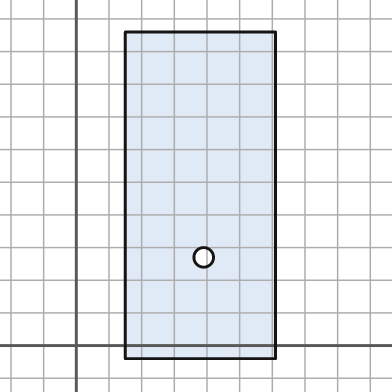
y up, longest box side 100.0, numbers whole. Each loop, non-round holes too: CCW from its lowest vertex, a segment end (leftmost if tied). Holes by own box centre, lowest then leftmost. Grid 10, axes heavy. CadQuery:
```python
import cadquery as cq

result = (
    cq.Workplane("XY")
    .moveTo(15.0, -4.0)
    .lineTo(61.0, -4.0)
    .lineTo(61.0, 96.0)
    .lineTo(15.0, 96.0)
    .close()
    .moveTo(39.0, 27.0)
    .circle(3.0)
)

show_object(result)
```